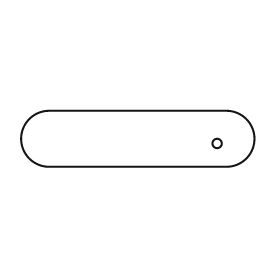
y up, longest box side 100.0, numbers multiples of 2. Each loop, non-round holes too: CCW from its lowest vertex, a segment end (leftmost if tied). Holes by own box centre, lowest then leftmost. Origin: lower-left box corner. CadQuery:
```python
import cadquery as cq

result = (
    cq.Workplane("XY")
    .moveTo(12.0, 0.0)
    .lineTo(88.0, 0.0)
    .threePointArc((100.0, 12.0), (88.0, 24.0))
    .lineTo(12.0, 24.0)
    .threePointArc((0.0, 12.0), (12.0, 0.0))
    .close()
    .moveTo(84.0, 10.0)
    .circle(2.0)
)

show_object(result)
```